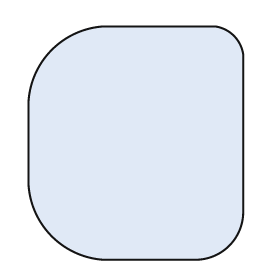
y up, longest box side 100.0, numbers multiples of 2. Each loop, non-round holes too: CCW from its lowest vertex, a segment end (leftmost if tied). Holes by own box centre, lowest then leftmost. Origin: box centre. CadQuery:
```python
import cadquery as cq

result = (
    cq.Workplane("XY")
    .moveTo(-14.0, -50.0)
    .lineTo(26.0, -50.0)
    .threePointArc((40.0, -44.0), (46.0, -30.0))
    .lineTo(46.0, 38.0)
    .threePointArc((42.0, 46.0), (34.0, 50.0))
    .lineTo(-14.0, 50.0)
    .threePointArc((-36.0, 40.0), (-46.0, 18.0))
    .lineTo(-46.0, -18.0)
    .threePointArc((-36.0, -40.0), (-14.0, -50.0))
    .close()
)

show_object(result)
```